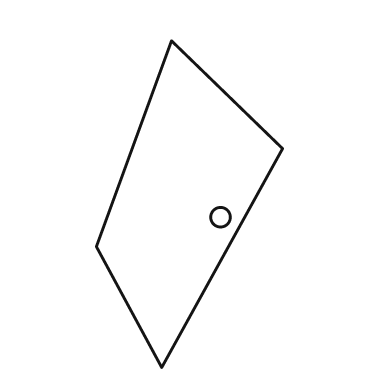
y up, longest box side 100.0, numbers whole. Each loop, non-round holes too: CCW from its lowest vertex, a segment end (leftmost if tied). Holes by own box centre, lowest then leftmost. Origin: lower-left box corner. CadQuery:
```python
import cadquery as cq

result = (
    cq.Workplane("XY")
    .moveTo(20.0, 0.0)
    .lineTo(57.0, 67.0)
    .lineTo(23.0, 100.0)
    .lineTo(0.0, 37.0)
    .close()
    .moveTo(38.0, 46.0)
    .circle(3.0)
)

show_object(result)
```